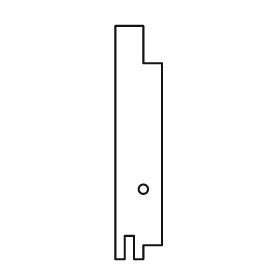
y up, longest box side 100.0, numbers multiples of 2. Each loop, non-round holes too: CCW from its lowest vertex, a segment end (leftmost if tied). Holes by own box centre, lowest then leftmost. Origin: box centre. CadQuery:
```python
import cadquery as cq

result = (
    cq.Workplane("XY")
    .moveTo(-10.0, -50.0)
    .lineTo(-6.0, -50.0)
    .lineTo(-6.0, -40.0)
    .lineTo(-2.0, -40.0)
    .lineTo(-2.0, -50.0)
    .lineTo(2.0, -50.0)
    .lineTo(2.0, -44.0)
    .lineTo(10.0, -44.0)
    .lineTo(10.0, 34.0)
    .lineTo(2.0, 34.0)
    .lineTo(2.0, 50.0)
    .lineTo(-10.0, 50.0)
    .close()
    .moveTo(2.0, -20.0)
    .circle(2.0)
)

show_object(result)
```